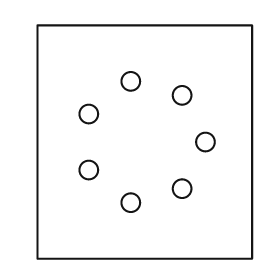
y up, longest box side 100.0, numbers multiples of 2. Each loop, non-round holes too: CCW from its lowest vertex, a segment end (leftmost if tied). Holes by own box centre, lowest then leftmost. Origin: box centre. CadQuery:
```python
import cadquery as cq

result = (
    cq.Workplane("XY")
    .moveTo(-46.0, -50.0)
    .lineTo(46.0, -50.0)
    .lineTo(46.0, 50.0)
    .lineTo(-46.0, 50.0)
    .close()
    .moveTo(-6.0, -26.0)
    .circle(4.0)
    .moveTo(16.0, -20.0)
    .circle(4.0)
    .moveTo(-24.0, -12.0)
    .circle(4.0)
    .moveTo(26.0, 0.0)
    .circle(4.0)
    .moveTo(-24.0, 12.0)
    .circle(4.0)
    .moveTo(16.0, 20.0)
    .circle(4.0)
    .moveTo(-6.0, 26.0)
    .circle(4.0)
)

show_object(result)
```